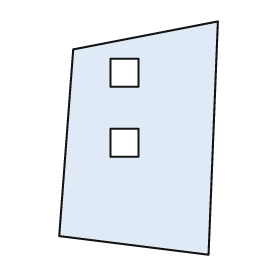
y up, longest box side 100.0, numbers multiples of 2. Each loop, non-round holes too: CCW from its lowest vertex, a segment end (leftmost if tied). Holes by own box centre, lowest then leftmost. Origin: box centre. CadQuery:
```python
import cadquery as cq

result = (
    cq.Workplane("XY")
    .moveTo(30.0, -50.0)
    .lineTo(34.0, 50.0)
    .lineTo(-28.0, 38.0)
    .lineTo(-34.0, -42.0)
    .close()
    .moveTo(-12.0, -8.0)
    .lineTo(0.0, -8.0)
    .lineTo(0.0, 4.0)
    .lineTo(-12.0, 4.0)
    .close()
    .moveTo(-12.0, 22.0)
    .lineTo(0.0, 22.0)
    .lineTo(0.0, 34.0)
    .lineTo(-12.0, 34.0)
    .close()
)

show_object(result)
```